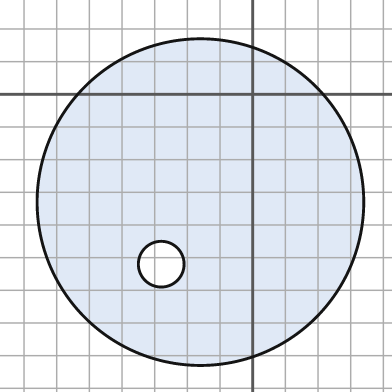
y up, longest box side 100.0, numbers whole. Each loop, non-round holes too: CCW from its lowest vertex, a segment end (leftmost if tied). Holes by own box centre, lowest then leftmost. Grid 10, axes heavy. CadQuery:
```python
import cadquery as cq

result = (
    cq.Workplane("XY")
    .moveTo(-16.0, -33.0)
    .circle(50.0)
    .moveTo(-28.0, -52.0)
    .circle(7.0)
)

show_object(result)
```